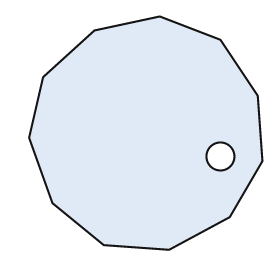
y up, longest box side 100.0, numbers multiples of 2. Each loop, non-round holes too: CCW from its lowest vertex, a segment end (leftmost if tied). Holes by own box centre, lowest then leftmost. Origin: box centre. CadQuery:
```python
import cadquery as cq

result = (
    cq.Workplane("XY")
    .moveTo(10.0, -50.0)
    .lineTo(36.0, -36.0)
    .lineTo(50.0, -12.0)
    .lineTo(48.0, 16.0)
    .lineTo(32.0, 40.0)
    .lineTo(6.0, 50.0)
    .lineTo(-22.0, 44.0)
    .lineTo(-44.0, 24.0)
    .lineTo(-50.0, -2.0)
    .lineTo(-40.0, -30.0)
    .lineTo(-18.0, -48.0)
    .close()
    .moveTo(32.0, -10.0)
    .circle(6.0)
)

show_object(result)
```